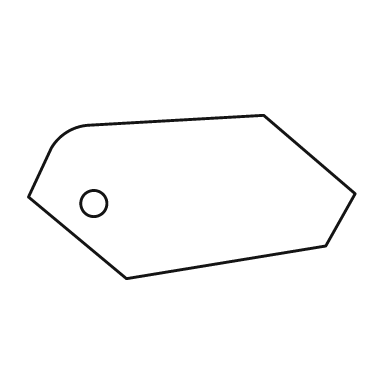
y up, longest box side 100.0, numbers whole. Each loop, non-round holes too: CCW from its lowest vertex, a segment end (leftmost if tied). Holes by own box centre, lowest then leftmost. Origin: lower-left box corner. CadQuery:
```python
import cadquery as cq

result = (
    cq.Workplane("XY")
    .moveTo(30.0, 0.0)
    .lineTo(91.0, 10.0)
    .lineTo(100.0, 26.0)
    .lineTo(72.0, 50.0)
    .lineTo(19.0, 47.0)
    .threePointArc((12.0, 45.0), (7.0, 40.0))
    .lineTo(0.0, 25.0)
    .close()
    .moveTo(20.0, 23.0)
    .circle(4.0)
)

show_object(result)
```